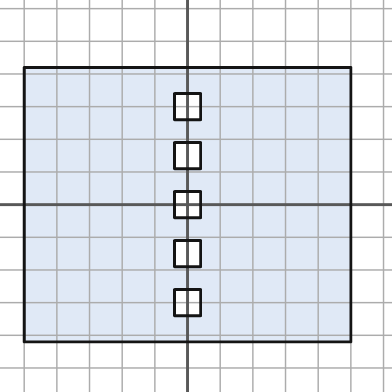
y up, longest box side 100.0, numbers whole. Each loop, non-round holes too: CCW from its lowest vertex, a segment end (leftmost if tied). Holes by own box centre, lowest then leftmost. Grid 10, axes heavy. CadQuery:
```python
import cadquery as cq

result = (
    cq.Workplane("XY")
    .moveTo(-50.0, -42.0)
    .lineTo(50.0, -42.0)
    .lineTo(50.0, 42.0)
    .lineTo(-50.0, 42.0)
    .close()
    .moveTo(-4.0, -34.0)
    .lineTo(4.0, -34.0)
    .lineTo(4.0, -26.0)
    .lineTo(-4.0, -26.0)
    .close()
    .moveTo(-4.0, -19.0)
    .lineTo(4.0, -19.0)
    .lineTo(4.0, -11.0)
    .lineTo(-4.0, -11.0)
    .close()
    .moveTo(-4.0, -4.0)
    .lineTo(4.0, -4.0)
    .lineTo(4.0, 4.0)
    .lineTo(-4.0, 4.0)
    .close()
    .moveTo(-4.0, 11.0)
    .lineTo(4.0, 11.0)
    .lineTo(4.0, 19.0)
    .lineTo(-4.0, 19.0)
    .close()
    .moveTo(-4.0, 26.0)
    .lineTo(4.0, 26.0)
    .lineTo(4.0, 34.0)
    .lineTo(-4.0, 34.0)
    .close()
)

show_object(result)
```